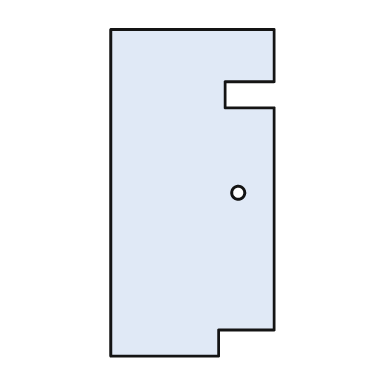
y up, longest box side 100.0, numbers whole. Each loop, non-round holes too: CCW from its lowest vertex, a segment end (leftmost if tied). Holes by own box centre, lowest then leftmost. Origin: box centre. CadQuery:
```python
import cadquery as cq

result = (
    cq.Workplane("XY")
    .moveTo(-25.0, -50.0)
    .lineTo(8.0, -50.0)
    .lineTo(8.0, -42.0)
    .lineTo(25.0, -42.0)
    .lineTo(25.0, 26.0)
    .lineTo(10.0, 26.0)
    .lineTo(10.0, 34.0)
    .lineTo(25.0, 34.0)
    .lineTo(25.0, 50.0)
    .lineTo(-25.0, 50.0)
    .close()
    .moveTo(14.0, 0.0)
    .circle(2.0)
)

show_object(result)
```